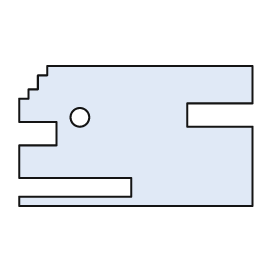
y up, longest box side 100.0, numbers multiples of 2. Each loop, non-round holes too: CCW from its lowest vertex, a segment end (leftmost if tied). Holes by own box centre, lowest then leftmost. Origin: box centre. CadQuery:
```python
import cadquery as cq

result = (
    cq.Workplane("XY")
    .moveTo(-50.0, -30.0)
    .lineTo(50.0, -30.0)
    .lineTo(50.0, 4.0)
    .lineTo(22.0, 4.0)
    .lineTo(22.0, 14.0)
    .lineTo(50.0, 14.0)
    .lineTo(50.0, 30.0)
    .lineTo(-38.0, 30.0)
    .lineTo(-38.0, 26.0)
    .lineTo(-42.0, 26.0)
    .lineTo(-42.0, 20.0)
    .lineTo(-46.0, 20.0)
    .lineTo(-46.0, 16.0)
    .lineTo(-50.0, 16.0)
    .lineTo(-50.0, 6.0)
    .lineTo(-34.0, 6.0)
    .lineTo(-34.0, -4.0)
    .lineTo(-50.0, -4.0)
    .lineTo(-50.0, -18.0)
    .lineTo(-2.0, -18.0)
    .lineTo(-2.0, -26.0)
    .lineTo(-50.0, -26.0)
    .close()
    .moveTo(-24.0, 8.0)
    .circle(4.0)
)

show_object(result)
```